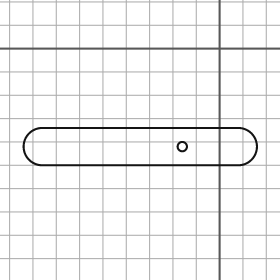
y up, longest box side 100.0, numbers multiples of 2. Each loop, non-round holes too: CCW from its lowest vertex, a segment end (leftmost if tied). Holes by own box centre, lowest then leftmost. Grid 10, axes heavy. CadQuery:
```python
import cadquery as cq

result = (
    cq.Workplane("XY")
    .moveTo(-76.0, -50.0)
    .lineTo(8.0, -50.0)
    .threePointArc((16.0, -42.0), (8.0, -34.0))
    .lineTo(-76.0, -34.0)
    .threePointArc((-84.0, -42.0), (-76.0, -50.0))
    .close()
    .moveTo(-16.0, -42.0)
    .circle(2.0)
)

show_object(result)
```